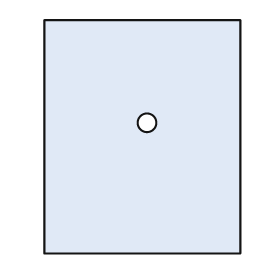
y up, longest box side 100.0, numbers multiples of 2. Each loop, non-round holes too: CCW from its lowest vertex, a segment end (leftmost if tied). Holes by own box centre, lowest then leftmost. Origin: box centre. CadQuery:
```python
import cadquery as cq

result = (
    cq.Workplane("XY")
    .moveTo(-42.0, -50.0)
    .lineTo(42.0, -50.0)
    .lineTo(42.0, 50.0)
    .lineTo(-42.0, 50.0)
    .close()
    .moveTo(2.0, 6.0)
    .circle(4.0)
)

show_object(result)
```